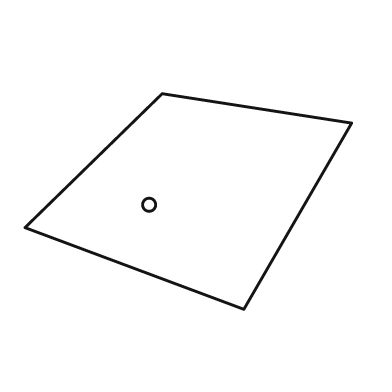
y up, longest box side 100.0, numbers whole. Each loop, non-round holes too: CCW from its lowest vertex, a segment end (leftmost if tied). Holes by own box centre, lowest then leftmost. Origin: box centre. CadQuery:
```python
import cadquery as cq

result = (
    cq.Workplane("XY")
    .moveTo(17.0, -33.0)
    .lineTo(50.0, 24.0)
    .lineTo(-8.0, 33.0)
    .lineTo(-50.0, -8.0)
    .close()
    .moveTo(-12.0, -1.0)
    .circle(2.0)
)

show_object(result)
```